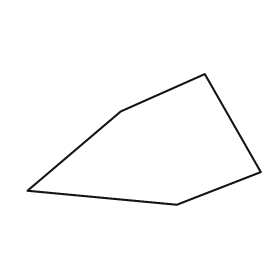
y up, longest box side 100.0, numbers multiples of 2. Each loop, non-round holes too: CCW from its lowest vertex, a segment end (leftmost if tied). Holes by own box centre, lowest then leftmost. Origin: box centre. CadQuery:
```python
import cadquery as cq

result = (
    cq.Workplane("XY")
    .moveTo(14.0, -28.0)
    .lineTo(50.0, -14.0)
    .lineTo(26.0, 28.0)
    .lineTo(-10.0, 12.0)
    .lineTo(-50.0, -22.0)
    .close()
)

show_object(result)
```